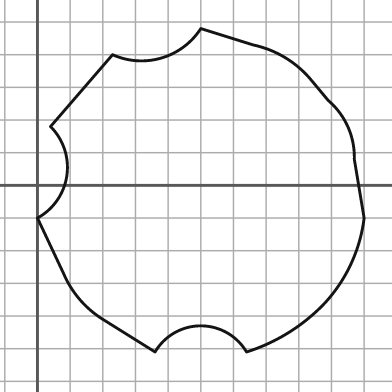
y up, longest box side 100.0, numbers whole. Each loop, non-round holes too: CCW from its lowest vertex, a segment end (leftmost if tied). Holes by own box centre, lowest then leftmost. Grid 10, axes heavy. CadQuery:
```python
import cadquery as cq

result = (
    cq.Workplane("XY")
    .moveTo(36.0, -51.0)
    .threePointArc((50.0, -43.0), (64.0, -51.0))
    .threePointArc((77.0, -45.0), (88.0, -36.0))
    .threePointArc((96.0, -24.0), (100.0, -10.0))
    .lineTo(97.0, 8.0)
    .threePointArc((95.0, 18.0), (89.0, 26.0))
    .lineTo(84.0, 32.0)
    .threePointArc((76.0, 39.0), (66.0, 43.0))
    .lineTo(50.0, 48.0)
    .threePointArc((38.0, 39.0), (23.0, 40.0))
    .lineTo(4.0, 18.0)
    .threePointArc((9.0, 3.0), (0.0, -10.0))
    .lineTo(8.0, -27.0)
    .threePointArc((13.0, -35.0), (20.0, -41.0))
    .close()
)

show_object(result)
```